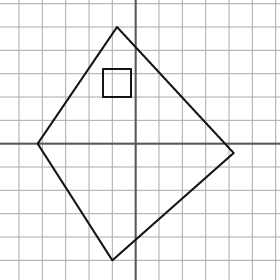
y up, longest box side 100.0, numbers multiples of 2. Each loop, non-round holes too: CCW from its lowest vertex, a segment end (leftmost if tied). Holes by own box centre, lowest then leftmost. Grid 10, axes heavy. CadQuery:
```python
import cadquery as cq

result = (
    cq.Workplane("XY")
    .moveTo(-10.0, -50.0)
    .lineTo(42.0, -4.0)
    .lineTo(-8.0, 50.0)
    .lineTo(-42.0, 0.0)
    .close()
    .moveTo(-14.0, 20.0)
    .lineTo(-2.0, 20.0)
    .lineTo(-2.0, 32.0)
    .lineTo(-14.0, 32.0)
    .close()
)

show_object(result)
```